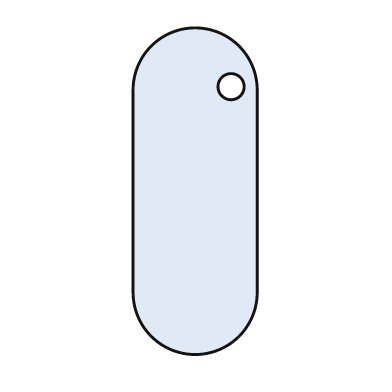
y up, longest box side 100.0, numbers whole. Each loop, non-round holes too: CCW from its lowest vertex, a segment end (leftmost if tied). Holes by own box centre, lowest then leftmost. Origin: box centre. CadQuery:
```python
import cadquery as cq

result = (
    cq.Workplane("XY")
    .moveTo(-19.0, -31.0)
    .threePointArc((0.0, -50.0), (19.0, -31.0))
    .lineTo(19.0, 31.0)
    .threePointArc((0.0, 50.0), (-19.0, 31.0))
    .close()
    .moveTo(11.0, 32.0)
    .circle(4.0)
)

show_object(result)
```